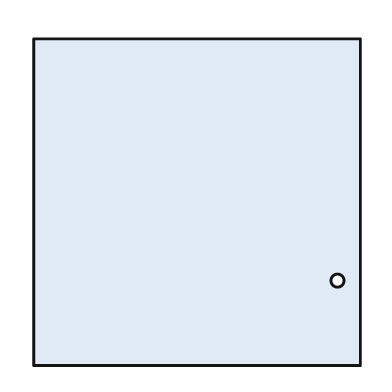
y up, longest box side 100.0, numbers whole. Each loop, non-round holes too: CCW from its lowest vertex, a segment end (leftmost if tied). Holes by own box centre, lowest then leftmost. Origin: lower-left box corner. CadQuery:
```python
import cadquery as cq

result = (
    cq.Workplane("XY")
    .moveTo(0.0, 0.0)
    .lineTo(100.0, 0.0)
    .lineTo(100.0, 100.0)
    .lineTo(0.0, 100.0)
    .close()
    .moveTo(93.0, 26.0)
    .circle(2.0)
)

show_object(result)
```